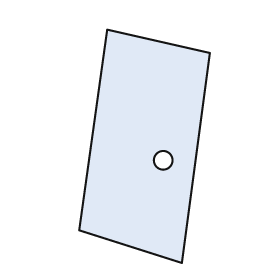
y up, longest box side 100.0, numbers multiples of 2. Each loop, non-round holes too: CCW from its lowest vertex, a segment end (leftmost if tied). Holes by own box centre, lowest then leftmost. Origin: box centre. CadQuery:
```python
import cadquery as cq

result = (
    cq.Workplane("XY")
    .moveTo(16.0, -50.0)
    .lineTo(28.0, 40.0)
    .lineTo(-16.0, 50.0)
    .lineTo(-28.0, -36.0)
    .close()
    .moveTo(8.0, -6.0)
    .circle(4.0)
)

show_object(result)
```